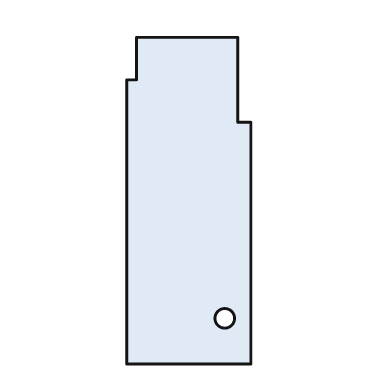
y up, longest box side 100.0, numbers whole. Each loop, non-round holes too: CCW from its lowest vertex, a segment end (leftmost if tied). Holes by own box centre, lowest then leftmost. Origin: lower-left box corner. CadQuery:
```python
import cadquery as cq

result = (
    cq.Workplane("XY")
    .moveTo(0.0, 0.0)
    .lineTo(38.0, 0.0)
    .lineTo(38.0, 74.0)
    .lineTo(34.0, 74.0)
    .lineTo(34.0, 100.0)
    .lineTo(3.0, 100.0)
    .lineTo(3.0, 87.0)
    .lineTo(0.0, 87.0)
    .close()
    .moveTo(30.0, 14.0)
    .circle(3.0)
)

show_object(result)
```